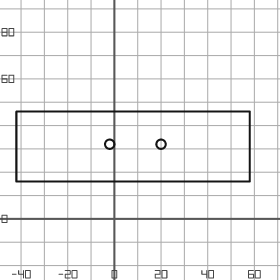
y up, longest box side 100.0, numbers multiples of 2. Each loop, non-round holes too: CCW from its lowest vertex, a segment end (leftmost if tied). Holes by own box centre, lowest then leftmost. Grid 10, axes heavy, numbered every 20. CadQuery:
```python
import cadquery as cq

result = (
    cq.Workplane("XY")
    .moveTo(-42.0, 16.0)
    .lineTo(58.0, 16.0)
    .lineTo(58.0, 46.0)
    .lineTo(-42.0, 46.0)
    .close()
    .moveTo(-2.0, 32.0)
    .circle(2.0)
    .moveTo(20.0, 32.0)
    .circle(2.0)
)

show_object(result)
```